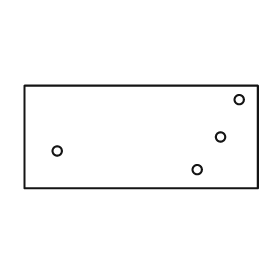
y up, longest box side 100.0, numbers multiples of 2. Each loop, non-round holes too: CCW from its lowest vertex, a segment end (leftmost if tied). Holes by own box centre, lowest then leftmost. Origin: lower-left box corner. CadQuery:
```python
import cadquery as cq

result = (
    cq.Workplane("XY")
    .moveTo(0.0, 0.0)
    .lineTo(100.0, 0.0)
    .lineTo(100.0, 44.0)
    .lineTo(0.0, 44.0)
    .close()
    .moveTo(74.0, 8.0)
    .circle(2.0)
    .moveTo(14.0, 16.0)
    .circle(2.0)
    .moveTo(84.0, 22.0)
    .circle(2.0)
    .moveTo(92.0, 38.0)
    .circle(2.0)
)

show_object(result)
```